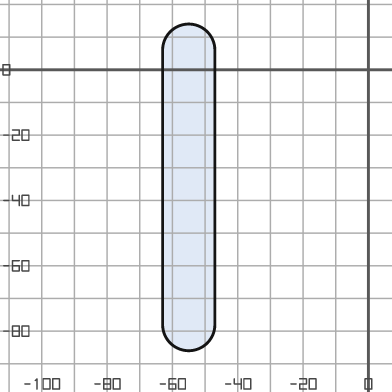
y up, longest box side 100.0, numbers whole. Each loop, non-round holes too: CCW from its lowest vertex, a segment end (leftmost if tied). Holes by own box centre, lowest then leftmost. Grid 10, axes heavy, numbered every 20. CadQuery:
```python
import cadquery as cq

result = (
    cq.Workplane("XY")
    .moveTo(-63.0, -78.0)
    .threePointArc((-55.0, -86.0), (-47.0, -78.0))
    .lineTo(-47.0, 6.0)
    .threePointArc((-55.0, 14.0), (-63.0, 6.0))
    .close()
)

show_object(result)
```